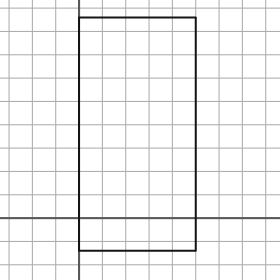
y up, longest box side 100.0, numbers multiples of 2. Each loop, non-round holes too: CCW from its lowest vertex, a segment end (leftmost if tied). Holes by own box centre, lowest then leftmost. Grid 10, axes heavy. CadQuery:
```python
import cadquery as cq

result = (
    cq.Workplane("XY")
    .moveTo(0.0, -14.0)
    .lineTo(50.0, -14.0)
    .lineTo(50.0, 86.0)
    .lineTo(0.0, 86.0)
    .close()
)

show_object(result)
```